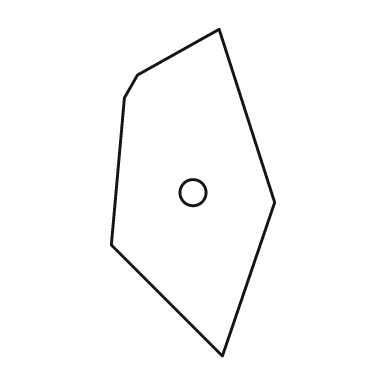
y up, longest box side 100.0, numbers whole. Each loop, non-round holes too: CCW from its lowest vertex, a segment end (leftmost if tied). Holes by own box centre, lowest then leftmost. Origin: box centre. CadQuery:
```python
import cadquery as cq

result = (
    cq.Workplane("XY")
    .moveTo(9.0, -50.0)
    .lineTo(25.0, -3.0)
    .lineTo(8.0, 50.0)
    .lineTo(-17.0, 36.0)
    .lineTo(-21.0, 29.0)
    .lineTo(-25.0, -16.0)
    .close()
    .moveTo(0.0, 0.0)
    .circle(4.0)
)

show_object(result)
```